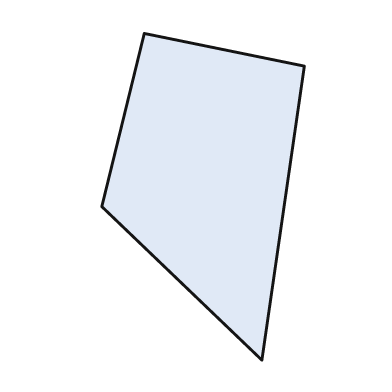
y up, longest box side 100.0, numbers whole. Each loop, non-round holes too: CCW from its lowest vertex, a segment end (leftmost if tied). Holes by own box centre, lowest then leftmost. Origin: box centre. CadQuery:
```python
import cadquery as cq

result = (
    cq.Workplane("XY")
    .moveTo(18.0, -50.0)
    .lineTo(31.0, 40.0)
    .lineTo(-18.0, 50.0)
    .lineTo(-31.0, -3.0)
    .close()
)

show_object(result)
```